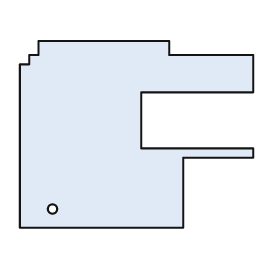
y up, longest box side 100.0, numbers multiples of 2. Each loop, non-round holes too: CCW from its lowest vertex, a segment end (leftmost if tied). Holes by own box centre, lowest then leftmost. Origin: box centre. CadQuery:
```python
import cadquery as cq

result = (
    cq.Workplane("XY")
    .moveTo(-50.0, -40.0)
    .lineTo(20.0, -40.0)
    .lineTo(20.0, -10.0)
    .lineTo(50.0, -10.0)
    .lineTo(50.0, -6.0)
    .lineTo(2.0, -6.0)
    .lineTo(2.0, 18.0)
    .lineTo(50.0, 18.0)
    .lineTo(50.0, 34.0)
    .lineTo(14.0, 34.0)
    .lineTo(14.0, 40.0)
    .lineTo(-42.0, 40.0)
    .lineTo(-42.0, 34.0)
    .lineTo(-46.0, 34.0)
    .lineTo(-46.0, 30.0)
    .lineTo(-50.0, 30.0)
    .close()
    .moveTo(-36.0, -32.0)
    .circle(2.0)
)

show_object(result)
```